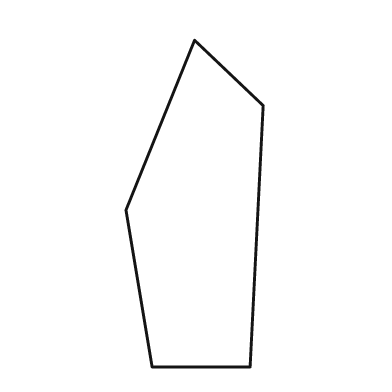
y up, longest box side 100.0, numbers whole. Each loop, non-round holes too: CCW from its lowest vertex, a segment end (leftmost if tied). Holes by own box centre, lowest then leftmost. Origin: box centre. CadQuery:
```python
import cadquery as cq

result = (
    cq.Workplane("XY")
    .moveTo(-13.0, -50.0)
    .lineTo(17.0, -50.0)
    .lineTo(21.0, 30.0)
    .lineTo(0.0, 50.0)
    .lineTo(-21.0, -2.0)
    .close()
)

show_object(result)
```